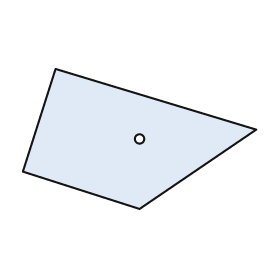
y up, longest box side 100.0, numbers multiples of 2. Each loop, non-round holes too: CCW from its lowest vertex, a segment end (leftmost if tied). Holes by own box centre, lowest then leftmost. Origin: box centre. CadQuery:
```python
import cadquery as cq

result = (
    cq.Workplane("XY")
    .moveTo(0.0, -30.0)
    .lineTo(50.0, 4.0)
    .lineTo(-36.0, 30.0)
    .lineTo(-50.0, -14.0)
    .close()
    .moveTo(0.0, 0.0)
    .circle(2.0)
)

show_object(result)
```